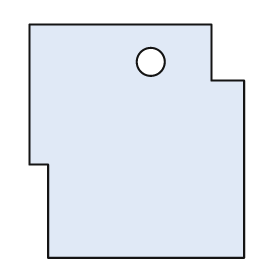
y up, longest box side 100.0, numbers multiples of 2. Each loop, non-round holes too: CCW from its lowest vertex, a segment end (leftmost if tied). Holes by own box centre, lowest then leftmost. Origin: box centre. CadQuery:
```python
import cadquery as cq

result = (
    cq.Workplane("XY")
    .moveTo(-38.0, -50.0)
    .lineTo(46.0, -50.0)
    .lineTo(46.0, 26.0)
    .lineTo(32.0, 26.0)
    .lineTo(32.0, 50.0)
    .lineTo(-46.0, 50.0)
    .lineTo(-46.0, -10.0)
    .lineTo(-38.0, -10.0)
    .close()
    .moveTo(6.0, 34.0)
    .circle(6.0)
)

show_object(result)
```